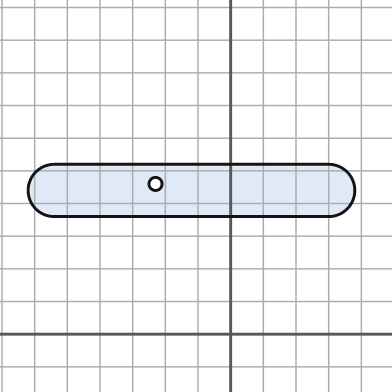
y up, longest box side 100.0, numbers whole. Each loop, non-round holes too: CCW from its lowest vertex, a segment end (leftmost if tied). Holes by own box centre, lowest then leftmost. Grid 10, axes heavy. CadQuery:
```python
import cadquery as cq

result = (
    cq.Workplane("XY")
    .moveTo(-54.0, 36.0)
    .lineTo(30.0, 36.0)
    .threePointArc((38.0, 44.0), (30.0, 52.0))
    .lineTo(-54.0, 52.0)
    .threePointArc((-62.0, 44.0), (-54.0, 36.0))
    .close()
    .moveTo(-23.0, 46.0)
    .circle(2.0)
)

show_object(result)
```